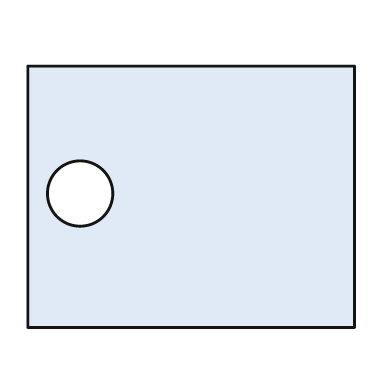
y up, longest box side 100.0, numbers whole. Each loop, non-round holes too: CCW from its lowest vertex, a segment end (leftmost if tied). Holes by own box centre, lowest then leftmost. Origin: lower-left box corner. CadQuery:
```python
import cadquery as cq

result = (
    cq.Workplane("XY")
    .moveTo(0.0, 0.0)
    .lineTo(100.0, 0.0)
    .lineTo(100.0, 80.0)
    .lineTo(0.0, 80.0)
    .close()
    .moveTo(16.0, 41.0)
    .circle(10.0)
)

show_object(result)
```